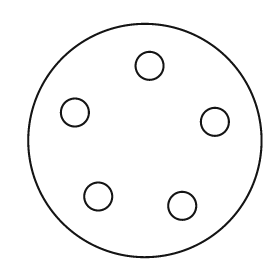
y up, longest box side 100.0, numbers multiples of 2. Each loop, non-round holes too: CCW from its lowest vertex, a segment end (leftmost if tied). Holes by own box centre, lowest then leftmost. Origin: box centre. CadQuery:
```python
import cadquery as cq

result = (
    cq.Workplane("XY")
    .moveTo(0.0, 0.0)
    .circle(50.0)
    .moveTo(16.0, -28.0)
    .circle(6.0)
    .moveTo(-20.0, -24.0)
    .circle(6.0)
    .moveTo(30.0, 8.0)
    .circle(6.0)
    .moveTo(-30.0, 12.0)
    .circle(6.0)
    .moveTo(2.0, 32.0)
    .circle(6.0)
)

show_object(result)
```